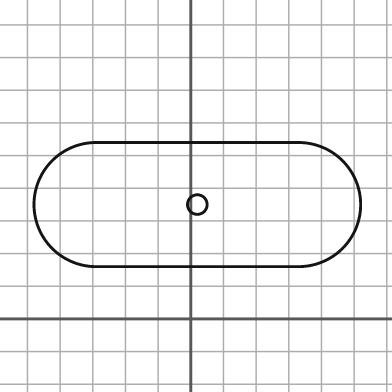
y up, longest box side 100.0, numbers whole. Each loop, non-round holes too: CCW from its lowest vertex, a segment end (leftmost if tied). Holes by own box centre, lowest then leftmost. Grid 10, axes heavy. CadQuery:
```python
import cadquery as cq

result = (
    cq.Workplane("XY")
    .moveTo(-29.0, 16.0)
    .lineTo(33.0, 16.0)
    .threePointArc((52.0, 35.0), (33.0, 54.0))
    .lineTo(-29.0, 54.0)
    .threePointArc((-48.0, 35.0), (-29.0, 16.0))
    .close()
    .moveTo(2.0, 35.0)
    .circle(3.0)
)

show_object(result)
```